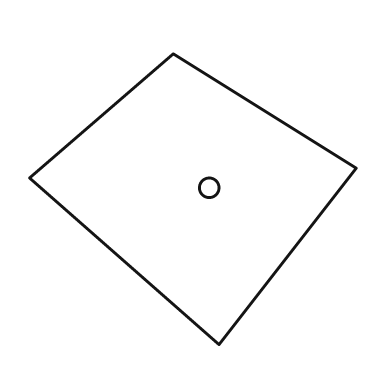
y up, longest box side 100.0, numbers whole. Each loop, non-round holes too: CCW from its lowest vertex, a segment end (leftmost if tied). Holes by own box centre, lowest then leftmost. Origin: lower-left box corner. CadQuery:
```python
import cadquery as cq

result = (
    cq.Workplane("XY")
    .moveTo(58.0, 0.0)
    .lineTo(100.0, 54.0)
    .lineTo(44.0, 89.0)
    .lineTo(0.0, 51.0)
    .close()
    .moveTo(55.0, 48.0)
    .circle(3.0)
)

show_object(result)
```